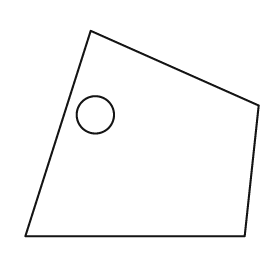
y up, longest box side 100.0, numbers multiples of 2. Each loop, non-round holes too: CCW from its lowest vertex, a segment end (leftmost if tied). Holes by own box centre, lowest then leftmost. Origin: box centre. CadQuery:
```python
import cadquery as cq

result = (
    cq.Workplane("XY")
    .moveTo(-50.0, -44.0)
    .lineTo(44.0, -44.0)
    .lineTo(50.0, 12.0)
    .lineTo(-22.0, 44.0)
    .close()
    .moveTo(-20.0, 8.0)
    .circle(8.0)
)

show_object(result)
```